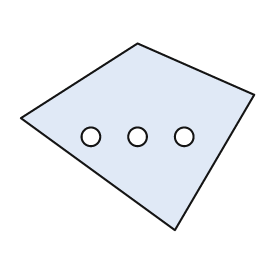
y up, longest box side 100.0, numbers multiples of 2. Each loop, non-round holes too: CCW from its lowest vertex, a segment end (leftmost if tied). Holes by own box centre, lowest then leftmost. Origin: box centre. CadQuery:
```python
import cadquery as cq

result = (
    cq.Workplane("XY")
    .moveTo(16.0, -40.0)
    .lineTo(50.0, 18.0)
    .lineTo(0.0, 40.0)
    .lineTo(-50.0, 8.0)
    .close()
    .moveTo(-20.0, 0.0)
    .circle(4.0)
    .moveTo(0.0, 0.0)
    .circle(4.0)
    .moveTo(20.0, 0.0)
    .circle(4.0)
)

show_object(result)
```